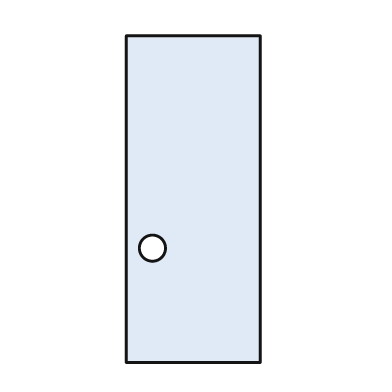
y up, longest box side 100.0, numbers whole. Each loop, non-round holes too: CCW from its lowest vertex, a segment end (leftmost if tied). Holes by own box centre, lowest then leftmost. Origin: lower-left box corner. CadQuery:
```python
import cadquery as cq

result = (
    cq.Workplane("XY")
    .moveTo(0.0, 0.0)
    .lineTo(41.0, 0.0)
    .lineTo(41.0, 100.0)
    .lineTo(0.0, 100.0)
    .close()
    .moveTo(8.0, 35.0)
    .circle(4.0)
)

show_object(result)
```